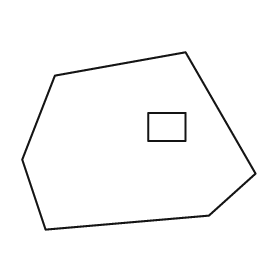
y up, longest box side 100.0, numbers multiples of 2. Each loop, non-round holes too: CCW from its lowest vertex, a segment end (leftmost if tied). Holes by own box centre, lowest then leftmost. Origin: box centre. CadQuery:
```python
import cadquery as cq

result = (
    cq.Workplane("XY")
    .moveTo(-40.0, -38.0)
    .lineTo(30.0, -32.0)
    .lineTo(50.0, -14.0)
    .lineTo(20.0, 38.0)
    .lineTo(-36.0, 28.0)
    .lineTo(-50.0, -8.0)
    .close()
    .moveTo(4.0, 0.0)
    .lineTo(20.0, 0.0)
    .lineTo(20.0, 12.0)
    .lineTo(4.0, 12.0)
    .close()
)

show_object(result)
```